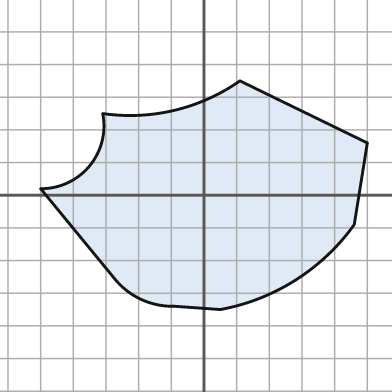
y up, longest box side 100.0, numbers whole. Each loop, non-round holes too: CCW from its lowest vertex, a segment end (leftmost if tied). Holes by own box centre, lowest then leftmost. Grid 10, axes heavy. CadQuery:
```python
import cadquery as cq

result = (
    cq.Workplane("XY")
    .moveTo(5.0, -35.0)
    .threePointArc((28.0, -26.0), (46.0, -9.0))
    .lineTo(50.0, 16.0)
    .lineTo(11.0, 35.0)
    .threePointArc((-9.0, 26.0), (-31.0, 25.0))
    .threePointArc((-35.0, 9.0), (-50.0, 2.0))
    .lineTo(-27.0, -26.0)
    .threePointArc((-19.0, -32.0), (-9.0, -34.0))
    .close()
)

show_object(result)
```